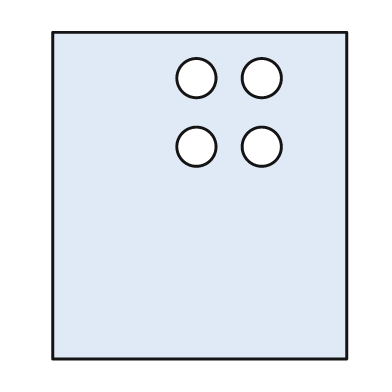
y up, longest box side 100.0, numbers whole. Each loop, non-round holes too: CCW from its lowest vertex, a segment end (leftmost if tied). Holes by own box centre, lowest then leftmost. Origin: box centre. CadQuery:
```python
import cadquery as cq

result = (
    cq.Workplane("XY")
    .moveTo(-45.0, -50.0)
    .lineTo(45.0, -50.0)
    .lineTo(45.0, 50.0)
    .lineTo(-45.0, 50.0)
    .close()
    .moveTo(-1.0, 15.0)
    .circle(6.0)
    .moveTo(19.0, 15.0)
    .circle(6.0)
    .moveTo(-1.0, 36.0)
    .circle(6.0)
    .moveTo(19.0, 36.0)
    .circle(6.0)
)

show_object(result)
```